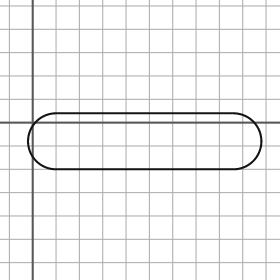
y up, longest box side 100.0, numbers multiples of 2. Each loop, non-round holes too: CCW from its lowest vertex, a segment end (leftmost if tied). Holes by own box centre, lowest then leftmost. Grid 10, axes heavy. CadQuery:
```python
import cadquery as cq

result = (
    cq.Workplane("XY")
    .moveTo(10.0, -20.0)
    .lineTo(86.0, -20.0)
    .threePointArc((98.0, -8.0), (86.0, 4.0))
    .lineTo(10.0, 4.0)
    .threePointArc((-2.0, -8.0), (10.0, -20.0))
    .close()
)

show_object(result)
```